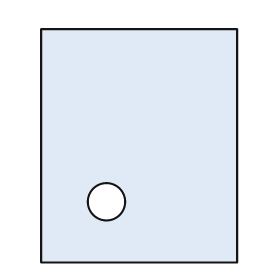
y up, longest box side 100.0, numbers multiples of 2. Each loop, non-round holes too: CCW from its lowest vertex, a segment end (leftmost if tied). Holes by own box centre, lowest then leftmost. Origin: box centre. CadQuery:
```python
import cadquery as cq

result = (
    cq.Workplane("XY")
    .moveTo(-42.0, -50.0)
    .lineTo(42.0, -50.0)
    .lineTo(42.0, 50.0)
    .lineTo(-42.0, 50.0)
    .close()
    .moveTo(-14.0, -24.0)
    .circle(8.0)
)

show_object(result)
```